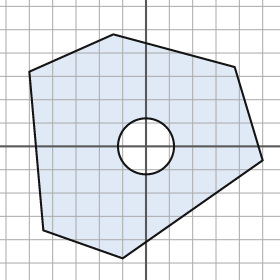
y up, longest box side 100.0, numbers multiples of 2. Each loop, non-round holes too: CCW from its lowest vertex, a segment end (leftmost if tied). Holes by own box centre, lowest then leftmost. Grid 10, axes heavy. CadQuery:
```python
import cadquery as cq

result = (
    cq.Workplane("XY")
    .moveTo(-10.0, -48.0)
    .lineTo(50.0, -6.0)
    .lineTo(38.0, 34.0)
    .lineTo(-14.0, 48.0)
    .lineTo(-50.0, 32.0)
    .lineTo(-44.0, -36.0)
    .close()
    .moveTo(0.0, 0.0)
    .circle(12.0)
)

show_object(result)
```